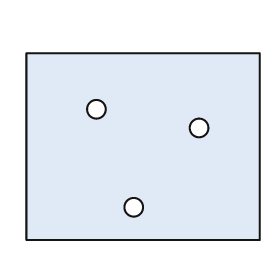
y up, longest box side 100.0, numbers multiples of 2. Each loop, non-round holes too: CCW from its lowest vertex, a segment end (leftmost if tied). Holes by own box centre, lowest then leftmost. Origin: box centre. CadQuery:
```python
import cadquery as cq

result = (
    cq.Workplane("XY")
    .moveTo(-50.0, -40.0)
    .lineTo(50.0, -40.0)
    .lineTo(50.0, 40.0)
    .lineTo(-50.0, 40.0)
    .close()
    .moveTo(-4.0, -26.0)
    .circle(4.0)
    .moveTo(24.0, 8.0)
    .circle(4.0)
    .moveTo(-20.0, 16.0)
    .circle(4.0)
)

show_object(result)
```